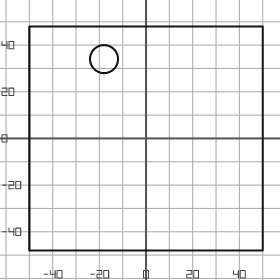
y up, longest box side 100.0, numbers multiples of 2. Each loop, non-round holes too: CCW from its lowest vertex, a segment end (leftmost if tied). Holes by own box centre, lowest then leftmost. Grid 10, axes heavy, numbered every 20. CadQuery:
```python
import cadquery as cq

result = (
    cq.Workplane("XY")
    .moveTo(-50.0, -48.0)
    .lineTo(50.0, -48.0)
    .lineTo(50.0, 48.0)
    .lineTo(-50.0, 48.0)
    .close()
    .moveTo(-18.0, 34.0)
    .circle(6.0)
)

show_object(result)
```